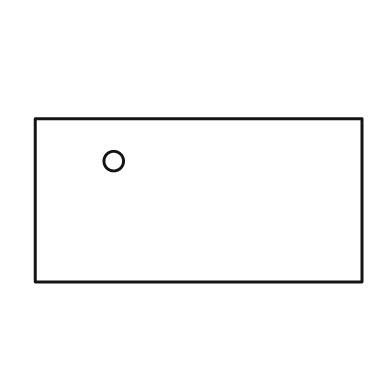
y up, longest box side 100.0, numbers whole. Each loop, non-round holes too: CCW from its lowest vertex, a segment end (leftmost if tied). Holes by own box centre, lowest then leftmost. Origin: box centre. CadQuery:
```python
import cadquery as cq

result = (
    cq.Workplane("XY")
    .moveTo(-50.0, -25.0)
    .lineTo(50.0, -25.0)
    .lineTo(50.0, 25.0)
    .lineTo(-50.0, 25.0)
    .close()
    .moveTo(-26.0, 12.0)
    .circle(3.0)
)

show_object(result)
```